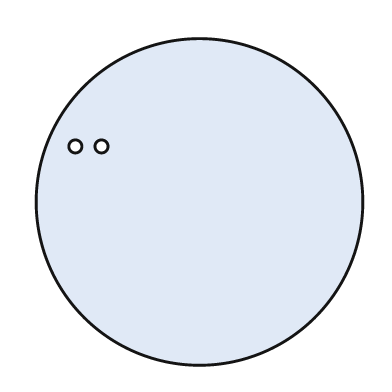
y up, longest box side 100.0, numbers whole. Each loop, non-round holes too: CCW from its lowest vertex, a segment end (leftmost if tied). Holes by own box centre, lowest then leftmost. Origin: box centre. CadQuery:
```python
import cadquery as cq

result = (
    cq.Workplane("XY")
    .moveTo(0.0, 0.0)
    .circle(50.0)
    .moveTo(-38.0, 17.0)
    .circle(2.0)
    .moveTo(-30.0, 17.0)
    .circle(2.0)
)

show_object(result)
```